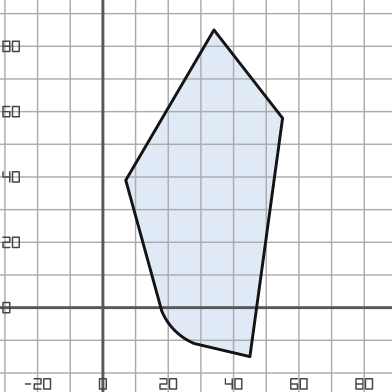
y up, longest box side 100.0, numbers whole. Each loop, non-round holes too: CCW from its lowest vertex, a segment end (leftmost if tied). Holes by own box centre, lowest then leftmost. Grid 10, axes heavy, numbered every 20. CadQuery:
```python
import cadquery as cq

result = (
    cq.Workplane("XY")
    .moveTo(45.0, -15.0)
    .lineTo(55.0, 58.0)
    .lineTo(34.0, 85.0)
    .lineTo(7.0, 39.0)
    .lineTo(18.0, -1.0)
    .threePointArc((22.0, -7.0), (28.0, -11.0))
    .close()
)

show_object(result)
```